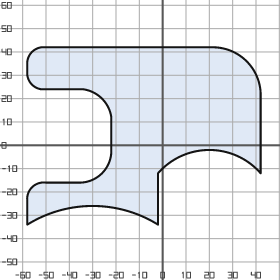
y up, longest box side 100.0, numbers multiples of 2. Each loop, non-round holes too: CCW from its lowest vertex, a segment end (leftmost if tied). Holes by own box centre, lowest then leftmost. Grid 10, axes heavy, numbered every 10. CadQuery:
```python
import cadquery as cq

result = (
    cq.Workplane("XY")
    .moveTo(-58.0, -34.0)
    .threePointArc((-30.0, -26.0), (-2.0, -34.0))
    .lineTo(-2.0, -12.0)
    .threePointArc((20.0, -2.0), (42.0, -12.0))
    .lineTo(42.0, 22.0)
    .threePointArc((36.0, 36.0), (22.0, 42.0))
    .lineTo(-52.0, 42.0)
    .threePointArc((-56.0, 40.0), (-58.0, 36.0))
    .lineTo(-58.0, 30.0)
    .threePointArc((-56.0, 26.0), (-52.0, 24.0))
    .lineTo(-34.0, 24.0)
    .threePointArc((-26.0, 20.0), (-22.0, 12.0))
    .lineTo(-22.0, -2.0)
    .threePointArc((-26.0, -12.0), (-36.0, -16.0))
    .lineTo(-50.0, -16.0)
    .threePointArc((-56.0, -18.0), (-58.0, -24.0))
    .close()
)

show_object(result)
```